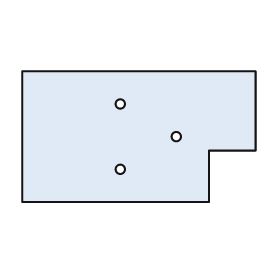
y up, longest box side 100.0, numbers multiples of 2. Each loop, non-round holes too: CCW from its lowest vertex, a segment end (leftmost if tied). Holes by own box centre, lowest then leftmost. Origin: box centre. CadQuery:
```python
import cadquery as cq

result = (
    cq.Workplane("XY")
    .moveTo(-50.0, -28.0)
    .lineTo(30.0, -28.0)
    .lineTo(30.0, -6.0)
    .lineTo(50.0, -6.0)
    .lineTo(50.0, 28.0)
    .lineTo(-50.0, 28.0)
    .close()
    .moveTo(-8.0, -14.0)
    .circle(2.0)
    .moveTo(16.0, 0.0)
    .circle(2.0)
    .moveTo(-8.0, 14.0)
    .circle(2.0)
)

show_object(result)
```